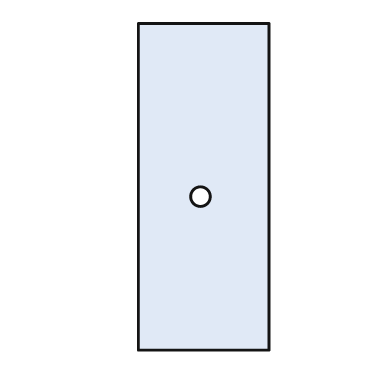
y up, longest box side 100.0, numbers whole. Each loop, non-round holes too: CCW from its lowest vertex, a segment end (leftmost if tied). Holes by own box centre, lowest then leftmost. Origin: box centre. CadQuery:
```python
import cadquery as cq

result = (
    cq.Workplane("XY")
    .moveTo(-20.0, -50.0)
    .lineTo(20.0, -50.0)
    .lineTo(20.0, 50.0)
    .lineTo(-20.0, 50.0)
    .close()
    .moveTo(-1.0, -3.0)
    .circle(3.0)
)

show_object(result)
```